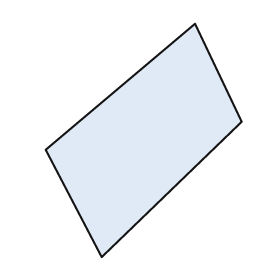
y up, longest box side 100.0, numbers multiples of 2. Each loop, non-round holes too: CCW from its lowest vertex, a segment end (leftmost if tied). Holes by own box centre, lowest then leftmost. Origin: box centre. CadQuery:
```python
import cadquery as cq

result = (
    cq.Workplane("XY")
    .moveTo(-18.0, -50.0)
    .lineTo(42.0, 8.0)
    .lineTo(22.0, 50.0)
    .lineTo(-42.0, -4.0)
    .close()
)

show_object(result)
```